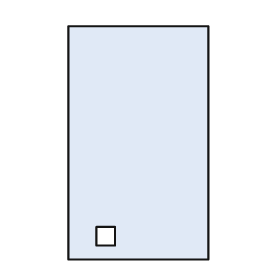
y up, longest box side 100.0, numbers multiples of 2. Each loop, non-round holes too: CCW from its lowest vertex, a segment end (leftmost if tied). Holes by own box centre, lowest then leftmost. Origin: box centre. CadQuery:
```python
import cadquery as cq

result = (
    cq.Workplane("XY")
    .moveTo(-30.0, -50.0)
    .lineTo(30.0, -50.0)
    .lineTo(30.0, 50.0)
    .lineTo(-30.0, 50.0)
    .close()
    .moveTo(-18.0, -44.0)
    .lineTo(-10.0, -44.0)
    .lineTo(-10.0, -36.0)
    .lineTo(-18.0, -36.0)
    .close()
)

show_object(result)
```